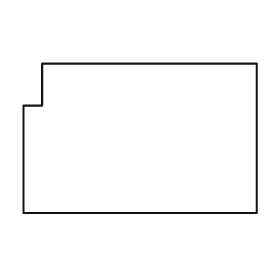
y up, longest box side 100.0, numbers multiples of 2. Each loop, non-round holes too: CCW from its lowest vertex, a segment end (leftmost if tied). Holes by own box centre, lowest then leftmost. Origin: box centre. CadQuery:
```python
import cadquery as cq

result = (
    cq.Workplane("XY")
    .moveTo(-50.0, -32.0)
    .lineTo(50.0, -32.0)
    .lineTo(50.0, 32.0)
    .lineTo(-42.0, 32.0)
    .lineTo(-42.0, 14.0)
    .lineTo(-50.0, 14.0)
    .close()
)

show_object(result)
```